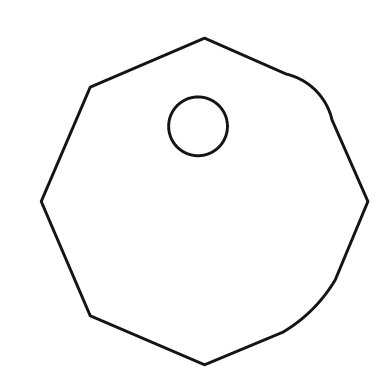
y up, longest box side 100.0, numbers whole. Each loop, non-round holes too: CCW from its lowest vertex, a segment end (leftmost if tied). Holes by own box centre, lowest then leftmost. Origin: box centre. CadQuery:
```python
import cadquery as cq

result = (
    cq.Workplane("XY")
    .moveTo(0.0, -50.0)
    .lineTo(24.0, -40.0)
    .threePointArc((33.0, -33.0), (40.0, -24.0))
    .lineTo(50.0, 0.0)
    .lineTo(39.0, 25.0)
    .threePointArc((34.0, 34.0), (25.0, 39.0))
    .lineTo(0.0, 50.0)
    .lineTo(-35.0, 35.0)
    .lineTo(-50.0, 0.0)
    .lineTo(-35.0, -35.0)
    .close()
    .moveTo(-2.0, 23.0)
    .circle(9.0)
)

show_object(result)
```